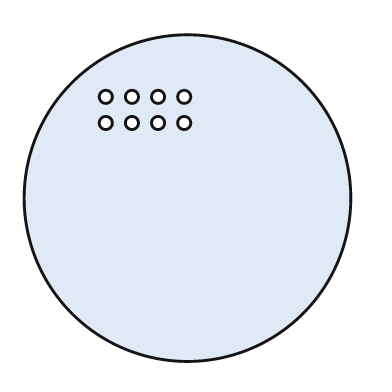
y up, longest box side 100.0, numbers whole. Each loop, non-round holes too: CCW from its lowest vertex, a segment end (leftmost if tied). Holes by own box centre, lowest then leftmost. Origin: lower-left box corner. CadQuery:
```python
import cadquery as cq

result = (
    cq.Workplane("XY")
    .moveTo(50.0, 50.0)
    .circle(50.0)
    .moveTo(25.0, 73.0)
    .circle(2.0)
    .moveTo(33.0, 73.0)
    .circle(2.0)
    .moveTo(41.0, 73.0)
    .circle(2.0)
    .moveTo(49.0, 73.0)
    .circle(2.0)
    .moveTo(25.0, 81.0)
    .circle(2.0)
    .moveTo(33.0, 81.0)
    .circle(2.0)
    .moveTo(41.0, 81.0)
    .circle(2.0)
    .moveTo(49.0, 81.0)
    .circle(2.0)
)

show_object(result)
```